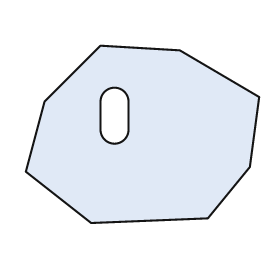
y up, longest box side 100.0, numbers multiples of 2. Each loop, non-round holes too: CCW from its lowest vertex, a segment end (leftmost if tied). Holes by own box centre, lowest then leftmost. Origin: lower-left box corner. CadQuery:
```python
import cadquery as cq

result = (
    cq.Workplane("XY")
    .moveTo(28.0, 0.0)
    .lineTo(78.0, 2.0)
    .lineTo(96.0, 24.0)
    .lineTo(100.0, 54.0)
    .lineTo(66.0, 74.0)
    .lineTo(32.0, 76.0)
    .lineTo(8.0, 52.0)
    .lineTo(0.0, 22.0)
    .close()
    .moveTo(32.0, 40.0)
    .threePointArc((38.0, 34.0), (44.0, 40.0))
    .lineTo(44.0, 52.0)
    .threePointArc((38.0, 58.0), (32.0, 52.0))
    .close()
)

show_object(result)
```